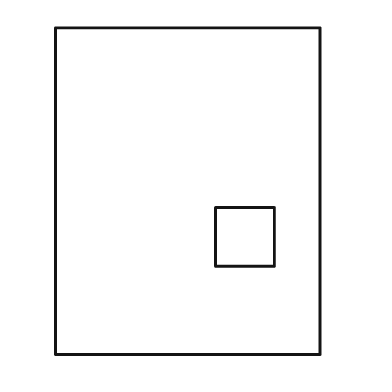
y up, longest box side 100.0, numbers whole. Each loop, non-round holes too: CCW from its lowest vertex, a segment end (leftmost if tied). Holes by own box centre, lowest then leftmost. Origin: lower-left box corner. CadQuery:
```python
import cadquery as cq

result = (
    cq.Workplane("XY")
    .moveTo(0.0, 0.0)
    .lineTo(81.0, 0.0)
    .lineTo(81.0, 100.0)
    .lineTo(0.0, 100.0)
    .close()
    .moveTo(49.0, 27.0)
    .lineTo(67.0, 27.0)
    .lineTo(67.0, 45.0)
    .lineTo(49.0, 45.0)
    .close()
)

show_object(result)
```